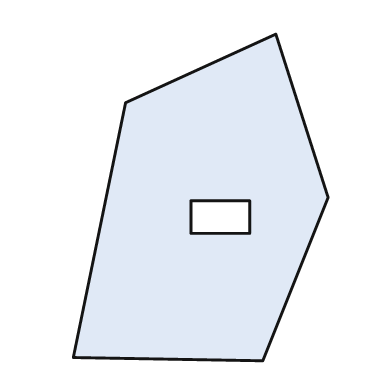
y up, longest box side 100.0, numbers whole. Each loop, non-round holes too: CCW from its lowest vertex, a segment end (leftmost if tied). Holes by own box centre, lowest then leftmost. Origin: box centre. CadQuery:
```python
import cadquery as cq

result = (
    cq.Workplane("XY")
    .moveTo(19.0, -50.0)
    .lineTo(39.0, 0.0)
    .lineTo(23.0, 50.0)
    .lineTo(-23.0, 29.0)
    .lineTo(-39.0, -49.0)
    .close()
    .moveTo(-3.0, -11.0)
    .lineTo(15.0, -11.0)
    .lineTo(15.0, -1.0)
    .lineTo(-3.0, -1.0)
    .close()
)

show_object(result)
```